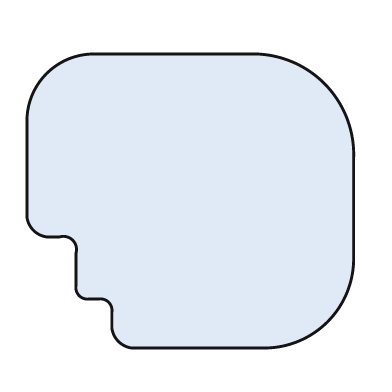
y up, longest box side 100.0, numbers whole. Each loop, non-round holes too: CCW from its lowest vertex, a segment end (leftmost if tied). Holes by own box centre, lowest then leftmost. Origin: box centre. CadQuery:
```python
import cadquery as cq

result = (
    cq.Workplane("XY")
    .moveTo(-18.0, -45.0)
    .lineTo(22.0, -45.0)
    .threePointArc((42.0, -37.0), (50.0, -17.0))
    .lineTo(50.0, 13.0)
    .threePointArc((41.0, 36.0), (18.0, 45.0))
    .lineTo(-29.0, 45.0)
    .threePointArc((-44.0, 39.0), (-50.0, 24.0))
    .lineTo(-50.0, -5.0)
    .threePointArc((-48.0, -9.0), (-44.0, -11.0))
    .lineTo(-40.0, -11.0)
    .threePointArc((-36.0, -12.0), (-35.0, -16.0))
    .lineTo(-35.0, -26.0)
    .threePointArc((-34.0, -29.0), (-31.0, -30.0))
    .lineTo(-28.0, -30.0)
    .threePointArc((-25.0, -31.0), (-24.0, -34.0))
    .lineTo(-24.0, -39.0)
    .threePointArc((-22.0, -43.0), (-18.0, -45.0))
    .close()
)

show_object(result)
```